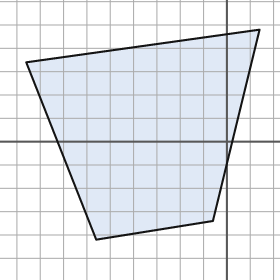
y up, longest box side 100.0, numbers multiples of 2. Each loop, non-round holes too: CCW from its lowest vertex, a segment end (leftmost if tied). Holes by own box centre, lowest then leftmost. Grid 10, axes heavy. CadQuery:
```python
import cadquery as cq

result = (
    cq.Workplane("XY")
    .moveTo(-56.0, -42.0)
    .lineTo(-6.0, -34.0)
    .lineTo(14.0, 48.0)
    .lineTo(-86.0, 34.0)
    .close()
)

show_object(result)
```